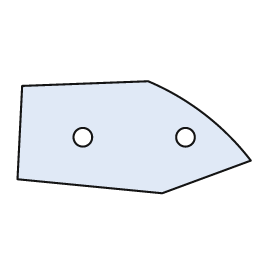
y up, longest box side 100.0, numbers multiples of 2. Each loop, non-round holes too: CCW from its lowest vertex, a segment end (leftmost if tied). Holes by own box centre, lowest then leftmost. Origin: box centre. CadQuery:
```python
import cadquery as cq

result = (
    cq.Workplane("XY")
    .moveTo(12.0, -24.0)
    .lineTo(50.0, -10.0)
    .threePointArc((30.0, 10.0), (6.0, 24.0))
    .lineTo(-48.0, 22.0)
    .lineTo(-50.0, -18.0)
    .close()
    .moveTo(-22.0, 0.0)
    .circle(4.0)
    .moveTo(22.0, 0.0)
    .circle(4.0)
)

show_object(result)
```